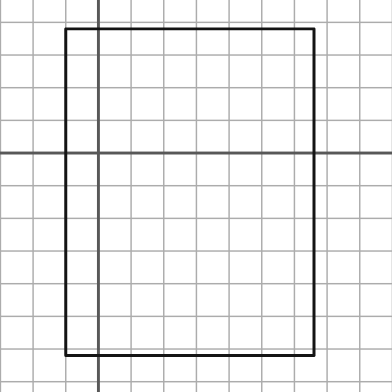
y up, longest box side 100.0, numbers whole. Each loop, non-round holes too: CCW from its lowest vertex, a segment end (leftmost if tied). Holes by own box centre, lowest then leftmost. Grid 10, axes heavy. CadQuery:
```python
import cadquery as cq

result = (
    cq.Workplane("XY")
    .moveTo(-10.0, -62.0)
    .lineTo(66.0, -62.0)
    .lineTo(66.0, 38.0)
    .lineTo(-10.0, 38.0)
    .close()
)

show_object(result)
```